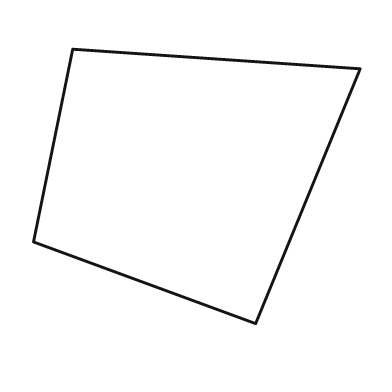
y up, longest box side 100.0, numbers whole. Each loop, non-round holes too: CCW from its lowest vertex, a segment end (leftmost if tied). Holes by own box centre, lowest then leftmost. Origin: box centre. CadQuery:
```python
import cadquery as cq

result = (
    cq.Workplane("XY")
    .moveTo(18.0, -42.0)
    .lineTo(50.0, 36.0)
    .lineTo(-38.0, 42.0)
    .lineTo(-50.0, -17.0)
    .close()
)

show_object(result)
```